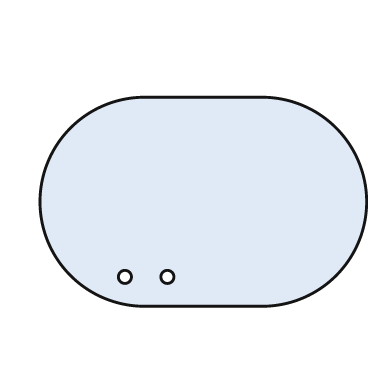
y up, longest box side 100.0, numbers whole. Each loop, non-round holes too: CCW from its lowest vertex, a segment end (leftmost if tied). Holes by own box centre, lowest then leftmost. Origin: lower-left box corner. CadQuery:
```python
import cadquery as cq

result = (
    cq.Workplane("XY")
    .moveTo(32.0, 0.0)
    .lineTo(68.0, 0.0)
    .threePointArc((100.0, 32.0), (68.0, 64.0))
    .lineTo(32.0, 64.0)
    .threePointArc((0.0, 32.0), (32.0, 0.0))
    .close()
    .moveTo(26.0, 9.0)
    .circle(2.0)
    .moveTo(39.0, 9.0)
    .circle(2.0)
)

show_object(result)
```